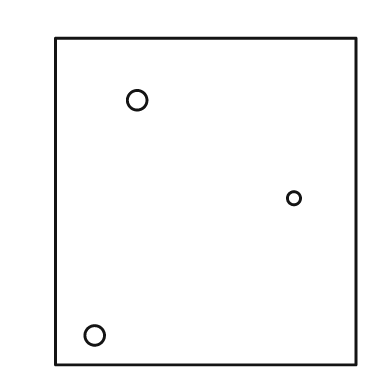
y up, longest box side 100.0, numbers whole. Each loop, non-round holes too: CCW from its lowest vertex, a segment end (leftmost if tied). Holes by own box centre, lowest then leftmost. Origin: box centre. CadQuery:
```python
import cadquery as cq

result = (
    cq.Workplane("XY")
    .moveTo(-46.0, -50.0)
    .lineTo(46.0, -50.0)
    .lineTo(46.0, 50.0)
    .lineTo(-46.0, 50.0)
    .close()
    .moveTo(-34.0, -41.0)
    .circle(3.0)
    .moveTo(27.0, 1.0)
    .circle(2.0)
    .moveTo(-21.0, 31.0)
    .circle(3.0)
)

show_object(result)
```